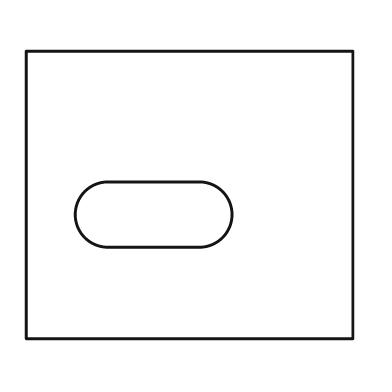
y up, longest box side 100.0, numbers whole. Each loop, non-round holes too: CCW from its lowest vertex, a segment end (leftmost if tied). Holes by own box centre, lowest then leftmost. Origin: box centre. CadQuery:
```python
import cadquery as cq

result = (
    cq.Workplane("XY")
    .moveTo(-50.0, -44.0)
    .lineTo(50.0, -44.0)
    .lineTo(50.0, 44.0)
    .lineTo(-50.0, 44.0)
    .close()
    .moveTo(-25.0, -16.0)
    .lineTo(3.0, -16.0)
    .threePointArc((13.0, -6.0), (3.0, 4.0))
    .lineTo(-25.0, 4.0)
    .threePointArc((-35.0, -6.0), (-25.0, -16.0))
    .close()
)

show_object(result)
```